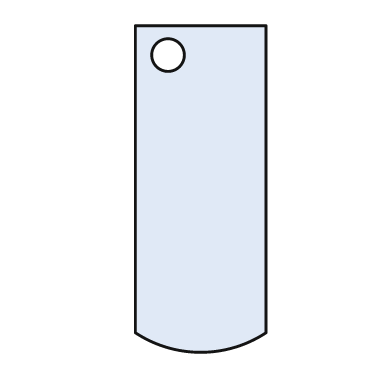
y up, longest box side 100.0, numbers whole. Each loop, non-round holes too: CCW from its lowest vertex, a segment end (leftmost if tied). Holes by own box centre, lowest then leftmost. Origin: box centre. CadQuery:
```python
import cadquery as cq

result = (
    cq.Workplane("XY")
    .moveTo(-20.0, -44.0)
    .threePointArc((0.0, -50.0), (20.0, -44.0))
    .lineTo(20.0, 50.0)
    .lineTo(-20.0, 50.0)
    .close()
    .moveTo(-10.0, 41.0)
    .circle(5.0)
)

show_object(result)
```